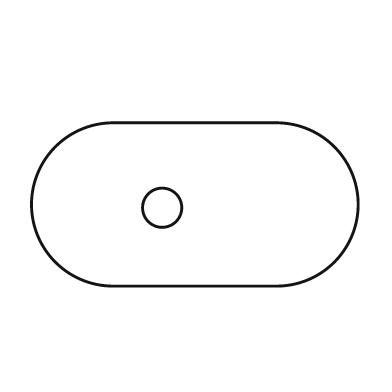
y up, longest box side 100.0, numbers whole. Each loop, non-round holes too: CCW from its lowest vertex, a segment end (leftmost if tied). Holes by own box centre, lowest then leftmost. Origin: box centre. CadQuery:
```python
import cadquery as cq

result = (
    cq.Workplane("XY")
    .moveTo(-25.0, -25.0)
    .lineTo(25.0, -25.0)
    .threePointArc((50.0, 0.0), (25.0, 25.0))
    .lineTo(-25.0, 25.0)
    .threePointArc((-50.0, 0.0), (-25.0, -25.0))
    .close()
    .moveTo(-10.0, -1.0)
    .circle(6.0)
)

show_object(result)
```